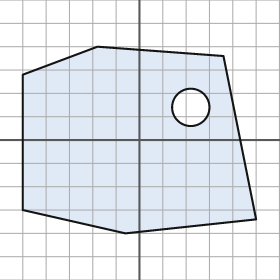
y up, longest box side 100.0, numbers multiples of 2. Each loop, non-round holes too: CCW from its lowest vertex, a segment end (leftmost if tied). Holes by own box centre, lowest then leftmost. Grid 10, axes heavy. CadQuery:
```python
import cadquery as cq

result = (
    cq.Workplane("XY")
    .moveTo(-6.0, -40.0)
    .lineTo(50.0, -34.0)
    .lineTo(36.0, 36.0)
    .lineTo(-18.0, 40.0)
    .lineTo(-50.0, 28.0)
    .lineTo(-50.0, -30.0)
    .close()
    .moveTo(22.0, 14.0)
    .circle(8.0)
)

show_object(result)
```